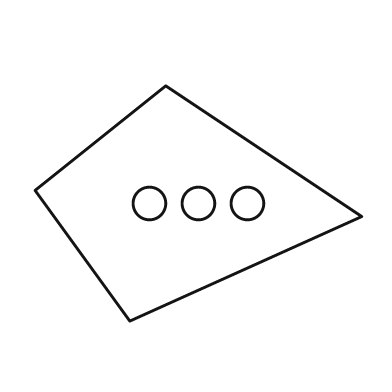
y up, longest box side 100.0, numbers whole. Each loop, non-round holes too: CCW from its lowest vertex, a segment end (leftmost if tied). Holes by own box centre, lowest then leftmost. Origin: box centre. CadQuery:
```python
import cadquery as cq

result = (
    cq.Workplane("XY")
    .moveTo(-21.0, -36.0)
    .lineTo(50.0, -4.0)
    .lineTo(-10.0, 36.0)
    .lineTo(-50.0, 4.0)
    .close()
    .moveTo(-15.0, 0.0)
    .circle(5.0)
    .moveTo(0.0, 0.0)
    .circle(5.0)
    .moveTo(15.0, 0.0)
    .circle(5.0)
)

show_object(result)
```